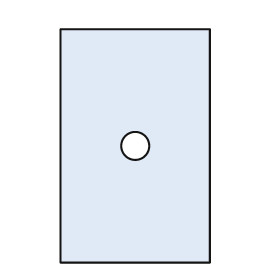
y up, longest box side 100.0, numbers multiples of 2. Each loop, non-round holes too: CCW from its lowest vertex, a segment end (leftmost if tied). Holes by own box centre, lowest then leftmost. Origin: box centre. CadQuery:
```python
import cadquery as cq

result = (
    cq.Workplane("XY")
    .moveTo(-32.0, -50.0)
    .lineTo(32.0, -50.0)
    .lineTo(32.0, 50.0)
    .lineTo(-32.0, 50.0)
    .close()
    .moveTo(0.0, 0.0)
    .circle(6.0)
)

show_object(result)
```